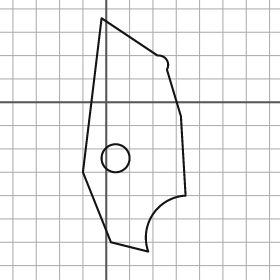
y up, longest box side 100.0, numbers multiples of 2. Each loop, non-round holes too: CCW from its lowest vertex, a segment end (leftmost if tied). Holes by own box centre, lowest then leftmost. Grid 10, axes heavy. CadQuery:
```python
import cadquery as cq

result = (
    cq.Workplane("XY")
    .moveTo(18.0, -64.0)
    .threePointArc((20.0, -48.0), (34.0, -40.0))
    .lineTo(32.0, -6.0)
    .lineTo(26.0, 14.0)
    .threePointArc((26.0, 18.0), (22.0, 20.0))
    .lineTo(-2.0, 36.0)
    .lineTo(-10.0, -30.0)
    .lineTo(2.0, -60.0)
    .close()
    .moveTo(4.0, -24.0)
    .circle(6.0)
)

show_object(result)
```